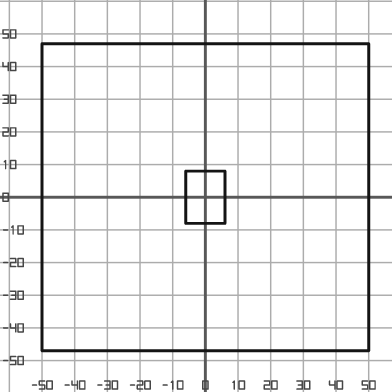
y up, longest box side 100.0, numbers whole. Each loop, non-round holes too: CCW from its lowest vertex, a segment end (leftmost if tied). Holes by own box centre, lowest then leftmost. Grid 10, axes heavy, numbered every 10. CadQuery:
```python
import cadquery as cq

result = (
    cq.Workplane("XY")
    .moveTo(-50.0, -47.0)
    .lineTo(50.0, -47.0)
    .lineTo(50.0, 47.0)
    .lineTo(-50.0, 47.0)
    .close()
    .moveTo(-6.0, -8.0)
    .lineTo(6.0, -8.0)
    .lineTo(6.0, 8.0)
    .lineTo(-6.0, 8.0)
    .close()
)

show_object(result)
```